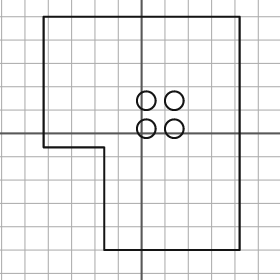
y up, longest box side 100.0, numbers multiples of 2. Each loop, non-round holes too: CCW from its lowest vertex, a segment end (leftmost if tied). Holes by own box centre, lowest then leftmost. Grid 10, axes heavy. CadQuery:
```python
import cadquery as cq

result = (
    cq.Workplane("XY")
    .moveTo(-16.0, -50.0)
    .lineTo(42.0, -50.0)
    .lineTo(42.0, 50.0)
    .lineTo(-42.0, 50.0)
    .lineTo(-42.0, -6.0)
    .lineTo(-16.0, -6.0)
    .close()
    .moveTo(2.0, 2.0)
    .circle(4.0)
    .moveTo(14.0, 2.0)
    .circle(4.0)
    .moveTo(2.0, 14.0)
    .circle(4.0)
    .moveTo(14.0, 14.0)
    .circle(4.0)
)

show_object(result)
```